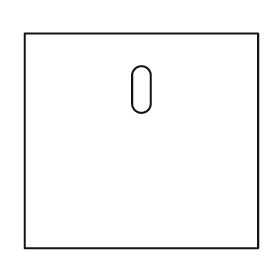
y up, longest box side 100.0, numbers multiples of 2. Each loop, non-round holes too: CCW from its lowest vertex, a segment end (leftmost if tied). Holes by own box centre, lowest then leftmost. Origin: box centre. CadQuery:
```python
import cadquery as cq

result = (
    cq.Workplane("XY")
    .moveTo(-50.0, -46.0)
    .lineTo(50.0, -46.0)
    .lineTo(50.0, 46.0)
    .lineTo(-50.0, 46.0)
    .close()
    .moveTo(-4.0, 16.0)
    .threePointArc((0.0, 12.0), (4.0, 16.0))
    .lineTo(4.0, 28.0)
    .threePointArc((0.0, 32.0), (-4.0, 28.0))
    .close()
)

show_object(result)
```